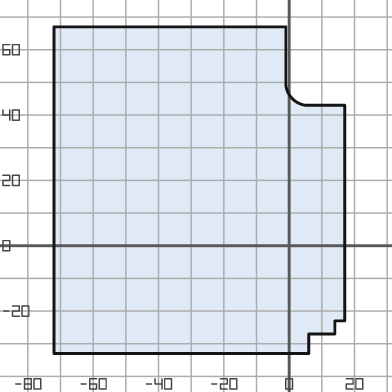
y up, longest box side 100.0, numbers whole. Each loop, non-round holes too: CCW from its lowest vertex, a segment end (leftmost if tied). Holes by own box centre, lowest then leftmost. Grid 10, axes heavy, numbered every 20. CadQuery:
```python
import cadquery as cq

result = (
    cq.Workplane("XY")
    .moveTo(-72.0, -33.0)
    .lineTo(6.0, -33.0)
    .lineTo(6.0, -27.0)
    .lineTo(14.0, -27.0)
    .lineTo(14.0, -23.0)
    .lineTo(17.0, -23.0)
    .lineTo(17.0, 43.0)
    .lineTo(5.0, 43.0)
    .threePointArc((1.0, 45.0), (-1.0, 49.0))
    .lineTo(-1.0, 67.0)
    .lineTo(-72.0, 67.0)
    .close()
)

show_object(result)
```